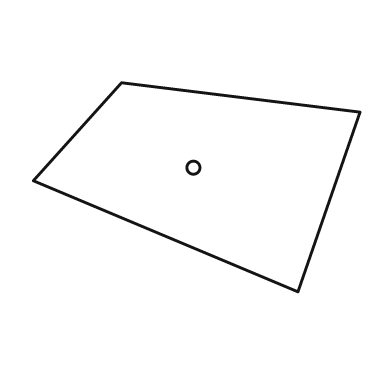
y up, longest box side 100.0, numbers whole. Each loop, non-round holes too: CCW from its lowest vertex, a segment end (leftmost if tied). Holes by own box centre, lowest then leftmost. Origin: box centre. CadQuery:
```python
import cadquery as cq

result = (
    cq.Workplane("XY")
    .moveTo(31.0, -32.0)
    .lineTo(50.0, 23.0)
    .lineTo(-23.0, 32.0)
    .lineTo(-50.0, 2.0)
    .close()
    .moveTo(-1.0, 6.0)
    .circle(2.0)
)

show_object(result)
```